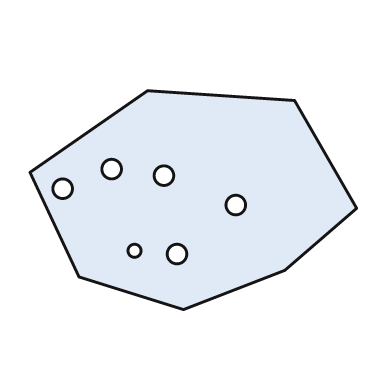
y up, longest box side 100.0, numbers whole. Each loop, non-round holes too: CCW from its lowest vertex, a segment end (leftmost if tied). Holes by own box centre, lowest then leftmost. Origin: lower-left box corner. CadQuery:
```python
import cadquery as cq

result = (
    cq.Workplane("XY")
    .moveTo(47.0, 0.0)
    .lineTo(78.0, 12.0)
    .lineTo(100.0, 31.0)
    .lineTo(81.0, 64.0)
    .lineTo(36.0, 67.0)
    .lineTo(0.0, 42.0)
    .lineTo(15.0, 10.0)
    .close()
    .moveTo(45.0, 17.0)
    .circle(3.0)
    .moveTo(32.0, 18.0)
    .circle(2.0)
    .moveTo(63.0, 32.0)
    .circle(3.0)
    .moveTo(10.0, 37.0)
    .circle(3.0)
    .moveTo(41.0, 41.0)
    .circle(3.0)
    .moveTo(25.0, 43.0)
    .circle(3.0)
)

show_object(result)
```